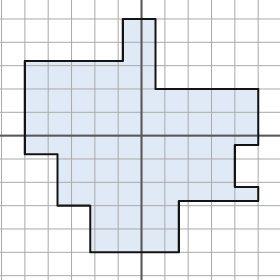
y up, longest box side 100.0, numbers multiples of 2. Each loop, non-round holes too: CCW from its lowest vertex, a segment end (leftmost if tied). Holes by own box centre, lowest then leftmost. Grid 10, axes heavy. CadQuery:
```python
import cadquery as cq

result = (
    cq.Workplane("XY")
    .moveTo(-22.0, -50.0)
    .lineTo(16.0, -50.0)
    .lineTo(16.0, -28.0)
    .lineTo(50.0, -28.0)
    .lineTo(50.0, -22.0)
    .lineTo(40.0, -22.0)
    .lineTo(40.0, -4.0)
    .lineTo(50.0, -4.0)
    .lineTo(50.0, 20.0)
    .lineTo(6.0, 20.0)
    .lineTo(6.0, 50.0)
    .lineTo(-8.0, 50.0)
    .lineTo(-8.0, 32.0)
    .lineTo(-50.0, 32.0)
    .lineTo(-50.0, -8.0)
    .lineTo(-36.0, -8.0)
    .lineTo(-36.0, -30.0)
    .lineTo(-22.0, -30.0)
    .close()
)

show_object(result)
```